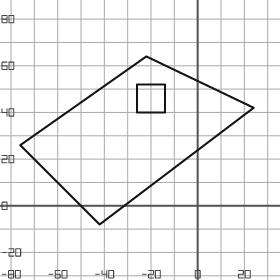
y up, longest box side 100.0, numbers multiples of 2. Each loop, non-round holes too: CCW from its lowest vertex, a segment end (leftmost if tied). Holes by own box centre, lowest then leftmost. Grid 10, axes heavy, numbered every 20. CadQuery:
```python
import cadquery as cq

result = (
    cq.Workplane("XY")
    .moveTo(-42.0, -8.0)
    .lineTo(24.0, 42.0)
    .lineTo(-22.0, 64.0)
    .lineTo(-76.0, 26.0)
    .close()
    .moveTo(-26.0, 40.0)
    .lineTo(-14.0, 40.0)
    .lineTo(-14.0, 52.0)
    .lineTo(-26.0, 52.0)
    .close()
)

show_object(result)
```